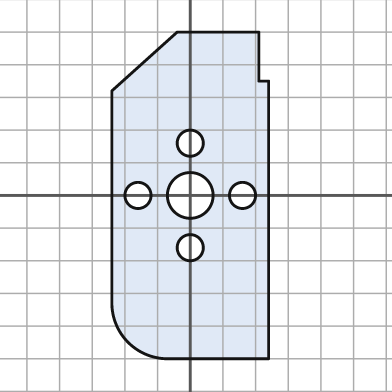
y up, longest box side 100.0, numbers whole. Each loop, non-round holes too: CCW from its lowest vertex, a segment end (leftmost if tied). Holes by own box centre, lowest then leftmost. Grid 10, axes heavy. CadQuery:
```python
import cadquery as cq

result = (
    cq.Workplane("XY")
    .moveTo(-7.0, -50.0)
    .lineTo(24.0, -50.0)
    .lineTo(24.0, 35.0)
    .lineTo(21.0, 35.0)
    .lineTo(21.0, 50.0)
    .lineTo(-4.0, 50.0)
    .lineTo(-24.0, 32.0)
    .lineTo(-24.0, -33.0)
    .threePointArc((-19.0, -45.0), (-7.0, -50.0))
    .close()
    .moveTo(0.0, -16.0)
    .circle(4.0)
    .moveTo(-16.0, 0.0)
    .circle(4.0)
    .moveTo(0.0, 0.0)
    .circle(7.0)
    .moveTo(16.0, 0.0)
    .circle(4.0)
    .moveTo(0.0, 16.0)
    .circle(4.0)
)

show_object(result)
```